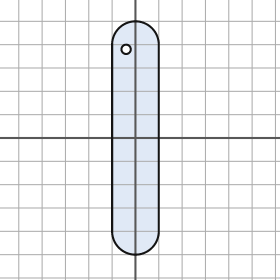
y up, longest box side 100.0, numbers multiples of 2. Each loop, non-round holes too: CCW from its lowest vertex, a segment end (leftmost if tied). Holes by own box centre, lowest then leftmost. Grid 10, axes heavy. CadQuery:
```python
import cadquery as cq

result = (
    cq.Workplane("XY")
    .moveTo(-10.0, -40.0)
    .threePointArc((0.0, -50.0), (10.0, -40.0))
    .lineTo(10.0, 40.0)
    .threePointArc((0.0, 50.0), (-10.0, 40.0))
    .close()
    .moveTo(-4.0, 38.0)
    .circle(2.0)
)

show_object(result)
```